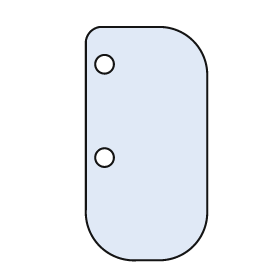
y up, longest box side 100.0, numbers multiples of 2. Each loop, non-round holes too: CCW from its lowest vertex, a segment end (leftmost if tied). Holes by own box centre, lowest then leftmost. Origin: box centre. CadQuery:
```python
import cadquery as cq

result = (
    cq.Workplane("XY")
    .moveTo(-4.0, -50.0)
    .lineTo(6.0, -50.0)
    .threePointArc((20.0, -44.0), (26.0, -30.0))
    .lineTo(26.0, 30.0)
    .threePointArc((20.0, 44.0), (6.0, 50.0))
    .lineTo(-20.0, 50.0)
    .threePointArc((-24.0, 48.0), (-26.0, 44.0))
    .lineTo(-26.0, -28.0)
    .threePointArc((-20.0, -44.0), (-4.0, -50.0))
    .close()
    .moveTo(-18.0, -6.0)
    .circle(4.0)
    .moveTo(-18.0, 34.0)
    .circle(4.0)
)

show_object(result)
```